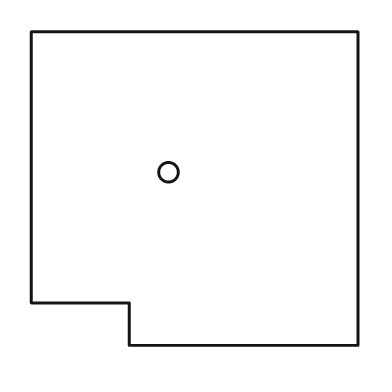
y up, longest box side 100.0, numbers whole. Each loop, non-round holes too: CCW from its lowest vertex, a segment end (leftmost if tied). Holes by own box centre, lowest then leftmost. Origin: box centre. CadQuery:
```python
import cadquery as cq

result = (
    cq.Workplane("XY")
    .moveTo(-20.0, -48.0)
    .lineTo(50.0, -48.0)
    .lineTo(50.0, 48.0)
    .lineTo(-50.0, 48.0)
    .lineTo(-50.0, -35.0)
    .lineTo(-20.0, -35.0)
    .close()
    .moveTo(-8.0, 5.0)
    .circle(3.0)
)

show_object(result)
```